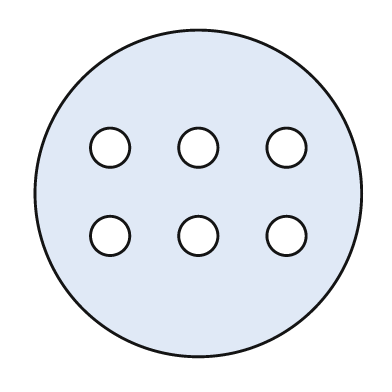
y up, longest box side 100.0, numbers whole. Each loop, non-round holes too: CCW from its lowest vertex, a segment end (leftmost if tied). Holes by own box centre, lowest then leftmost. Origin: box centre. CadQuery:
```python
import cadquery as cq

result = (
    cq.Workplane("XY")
    .moveTo(0.0, 0.0)
    .circle(50.0)
    .moveTo(-27.0, -13.0)
    .circle(6.0)
    .moveTo(0.0, -13.0)
    .circle(6.0)
    .moveTo(27.0, -13.0)
    .circle(6.0)
    .moveTo(-27.0, 14.0)
    .circle(6.0)
    .moveTo(0.0, 14.0)
    .circle(6.0)
    .moveTo(27.0, 14.0)
    .circle(6.0)
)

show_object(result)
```